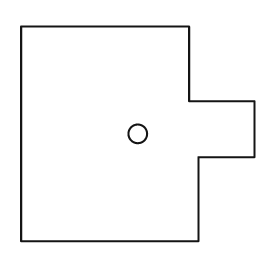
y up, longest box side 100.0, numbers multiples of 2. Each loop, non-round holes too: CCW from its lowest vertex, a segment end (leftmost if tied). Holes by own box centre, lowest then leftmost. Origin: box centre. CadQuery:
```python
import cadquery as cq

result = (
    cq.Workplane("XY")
    .moveTo(-50.0, -46.0)
    .lineTo(26.0, -46.0)
    .lineTo(26.0, -10.0)
    .lineTo(50.0, -10.0)
    .lineTo(50.0, 14.0)
    .lineTo(22.0, 14.0)
    .lineTo(22.0, 46.0)
    .lineTo(-50.0, 46.0)
    .close()
    .moveTo(0.0, 0.0)
    .circle(4.0)
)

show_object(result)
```